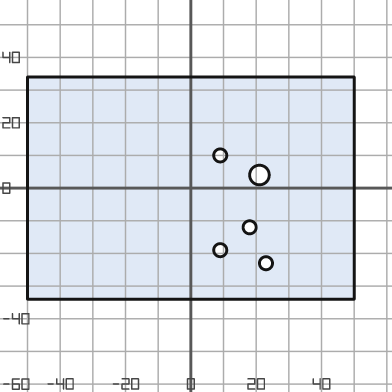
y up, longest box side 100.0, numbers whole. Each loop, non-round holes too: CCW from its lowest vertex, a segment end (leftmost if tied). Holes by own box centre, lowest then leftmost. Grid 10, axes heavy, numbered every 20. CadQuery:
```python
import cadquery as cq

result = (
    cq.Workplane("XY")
    .moveTo(-50.0, -34.0)
    .lineTo(50.0, -34.0)
    .lineTo(50.0, 34.0)
    .lineTo(-50.0, 34.0)
    .close()
    .moveTo(23.0, -23.0)
    .circle(2.0)
    .moveTo(9.0, -19.0)
    .circle(2.0)
    .moveTo(18.0, -12.0)
    .circle(2.0)
    .moveTo(21.0, 4.0)
    .circle(3.0)
    .moveTo(9.0, 10.0)
    .circle(2.0)
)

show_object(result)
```